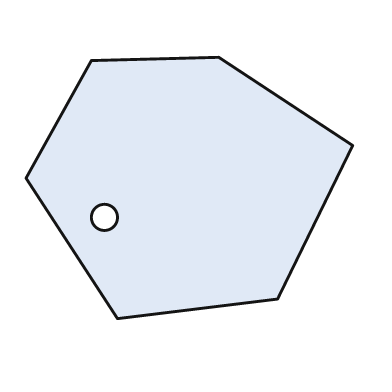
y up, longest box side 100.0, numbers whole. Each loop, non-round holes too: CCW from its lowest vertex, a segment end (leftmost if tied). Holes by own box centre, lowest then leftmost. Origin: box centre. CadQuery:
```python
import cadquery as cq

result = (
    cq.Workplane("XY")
    .moveTo(-22.0, -40.0)
    .lineTo(27.0, -34.0)
    .lineTo(50.0, 13.0)
    .lineTo(9.0, 40.0)
    .lineTo(-30.0, 39.0)
    .lineTo(-50.0, 3.0)
    .close()
    .moveTo(-26.0, -9.0)
    .circle(4.0)
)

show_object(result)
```